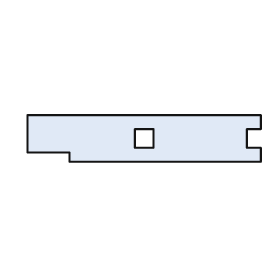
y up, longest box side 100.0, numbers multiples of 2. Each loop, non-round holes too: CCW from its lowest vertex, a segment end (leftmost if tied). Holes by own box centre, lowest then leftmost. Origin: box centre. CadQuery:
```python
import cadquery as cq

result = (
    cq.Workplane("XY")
    .moveTo(-32.0, -10.0)
    .lineTo(50.0, -10.0)
    .lineTo(50.0, -4.0)
    .lineTo(44.0, -4.0)
    .lineTo(44.0, 4.0)
    .lineTo(50.0, 4.0)
    .lineTo(50.0, 10.0)
    .lineTo(-50.0, 10.0)
    .lineTo(-50.0, -6.0)
    .lineTo(-32.0, -6.0)
    .close()
    .moveTo(-4.0, -4.0)
    .lineTo(4.0, -4.0)
    .lineTo(4.0, 4.0)
    .lineTo(-4.0, 4.0)
    .close()
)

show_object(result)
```